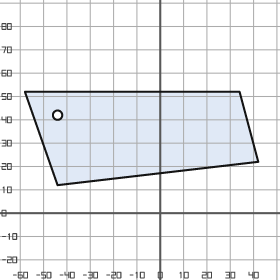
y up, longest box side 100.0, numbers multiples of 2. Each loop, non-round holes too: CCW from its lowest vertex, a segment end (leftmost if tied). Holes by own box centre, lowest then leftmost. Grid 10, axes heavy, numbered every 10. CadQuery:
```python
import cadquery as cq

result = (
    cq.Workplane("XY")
    .moveTo(-44.0, 12.0)
    .lineTo(42.0, 22.0)
    .lineTo(34.0, 52.0)
    .lineTo(-58.0, 52.0)
    .close()
    .moveTo(-44.0, 42.0)
    .circle(2.0)
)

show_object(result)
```